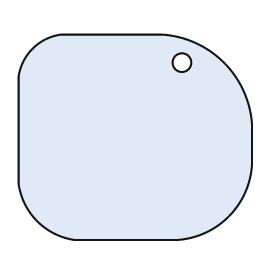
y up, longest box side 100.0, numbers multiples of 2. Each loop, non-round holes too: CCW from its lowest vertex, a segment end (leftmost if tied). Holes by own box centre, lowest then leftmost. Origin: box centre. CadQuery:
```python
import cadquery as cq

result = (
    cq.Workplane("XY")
    .moveTo(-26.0, -44.0)
    .lineTo(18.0, -44.0)
    .threePointArc((40.0, -34.0), (50.0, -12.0))
    .lineTo(50.0, 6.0)
    .threePointArc((38.0, 32.0), (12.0, 44.0))
    .lineTo(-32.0, 44.0)
    .threePointArc((-44.0, 38.0), (-50.0, 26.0))
    .lineTo(-50.0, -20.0)
    .threePointArc((-42.0, -36.0), (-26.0, -44.0))
    .close()
    .moveTo(20.0, 32.0)
    .circle(4.0)
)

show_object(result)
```